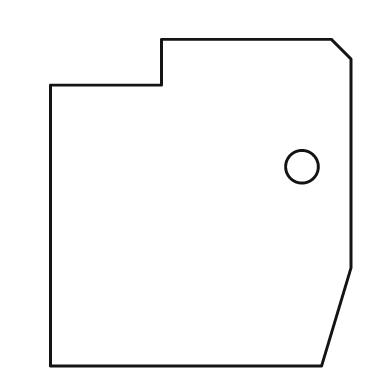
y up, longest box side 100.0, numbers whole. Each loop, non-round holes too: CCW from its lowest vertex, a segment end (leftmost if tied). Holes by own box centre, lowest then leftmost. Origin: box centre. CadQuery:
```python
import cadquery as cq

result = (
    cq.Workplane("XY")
    .moveTo(-46.0, -50.0)
    .lineTo(37.0, -50.0)
    .lineTo(46.0, -20.0)
    .lineTo(46.0, 44.0)
    .lineTo(40.0, 50.0)
    .lineTo(-12.0, 50.0)
    .lineTo(-12.0, 36.0)
    .lineTo(-46.0, 36.0)
    .close()
    .moveTo(31.0, 11.0)
    .circle(5.0)
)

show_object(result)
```